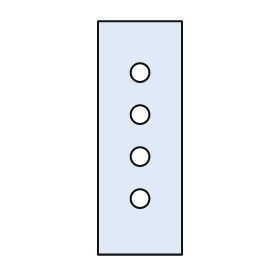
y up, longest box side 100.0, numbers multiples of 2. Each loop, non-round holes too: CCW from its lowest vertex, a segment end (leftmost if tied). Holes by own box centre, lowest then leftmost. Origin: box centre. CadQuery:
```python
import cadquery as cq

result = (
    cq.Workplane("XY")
    .moveTo(-18.0, -50.0)
    .lineTo(18.0, -50.0)
    .lineTo(18.0, 50.0)
    .lineTo(-18.0, 50.0)
    .close()
    .moveTo(0.0, -26.0)
    .circle(4.0)
    .moveTo(0.0, -8.0)
    .circle(4.0)
    .moveTo(0.0, 10.0)
    .circle(4.0)
    .moveTo(0.0, 28.0)
    .circle(4.0)
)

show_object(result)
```